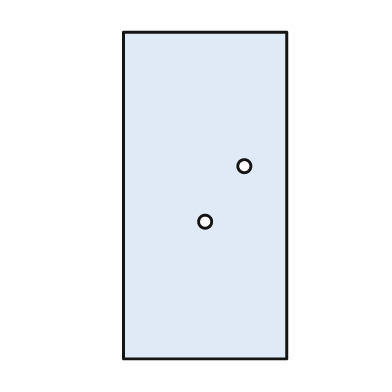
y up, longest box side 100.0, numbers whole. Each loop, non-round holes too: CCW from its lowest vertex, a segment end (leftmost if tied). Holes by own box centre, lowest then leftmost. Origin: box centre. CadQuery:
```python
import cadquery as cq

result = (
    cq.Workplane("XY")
    .moveTo(-25.0, -50.0)
    .lineTo(25.0, -50.0)
    .lineTo(25.0, 50.0)
    .lineTo(-25.0, 50.0)
    .close()
    .moveTo(0.0, -8.0)
    .circle(2.0)
    .moveTo(12.0, 9.0)
    .circle(2.0)
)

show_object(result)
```